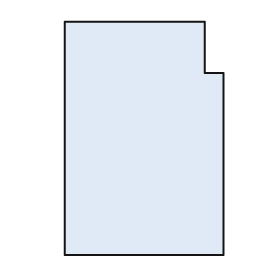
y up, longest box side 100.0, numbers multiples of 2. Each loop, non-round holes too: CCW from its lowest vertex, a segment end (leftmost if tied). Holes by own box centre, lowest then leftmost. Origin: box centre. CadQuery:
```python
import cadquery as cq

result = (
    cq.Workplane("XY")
    .moveTo(-34.0, -50.0)
    .lineTo(34.0, -50.0)
    .lineTo(34.0, 28.0)
    .lineTo(26.0, 28.0)
    .lineTo(26.0, 50.0)
    .lineTo(-34.0, 50.0)
    .close()
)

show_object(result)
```